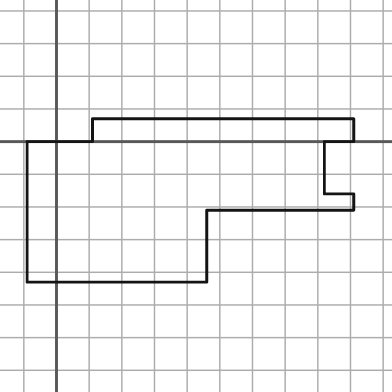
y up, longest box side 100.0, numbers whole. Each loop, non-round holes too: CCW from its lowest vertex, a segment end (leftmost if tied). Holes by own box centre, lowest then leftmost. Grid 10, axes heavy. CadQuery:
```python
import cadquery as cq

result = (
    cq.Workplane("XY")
    .moveTo(-9.0, -43.0)
    .lineTo(46.0, -43.0)
    .lineTo(46.0, -21.0)
    .lineTo(91.0, -21.0)
    .lineTo(91.0, -16.0)
    .lineTo(82.0, -16.0)
    .lineTo(82.0, 0.0)
    .lineTo(91.0, 0.0)
    .lineTo(91.0, 7.0)
    .lineTo(11.0, 7.0)
    .lineTo(11.0, 0.0)
    .lineTo(-9.0, 0.0)
    .close()
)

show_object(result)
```